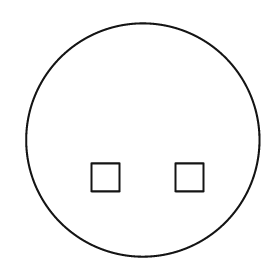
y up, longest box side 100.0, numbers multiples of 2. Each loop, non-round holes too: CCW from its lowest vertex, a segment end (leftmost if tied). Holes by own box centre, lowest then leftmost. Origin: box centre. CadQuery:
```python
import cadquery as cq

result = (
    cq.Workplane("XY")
    .moveTo(0.0, 0.0)
    .circle(50.0)
    .moveTo(-22.0, -22.0)
    .lineTo(-10.0, -22.0)
    .lineTo(-10.0, -10.0)
    .lineTo(-22.0, -10.0)
    .close()
    .moveTo(14.0, -22.0)
    .lineTo(26.0, -22.0)
    .lineTo(26.0, -10.0)
    .lineTo(14.0, -10.0)
    .close()
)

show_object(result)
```